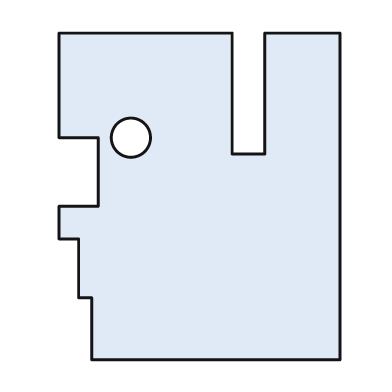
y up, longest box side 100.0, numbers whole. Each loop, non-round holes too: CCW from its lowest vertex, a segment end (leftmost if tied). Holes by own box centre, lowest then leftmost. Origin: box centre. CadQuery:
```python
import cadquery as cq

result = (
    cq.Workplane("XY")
    .moveTo(-33.0, -50.0)
    .lineTo(43.0, -50.0)
    .lineTo(43.0, 50.0)
    .lineTo(20.0, 50.0)
    .lineTo(20.0, 13.0)
    .lineTo(10.0, 13.0)
    .lineTo(10.0, 50.0)
    .lineTo(-43.0, 50.0)
    .lineTo(-43.0, 18.0)
    .lineTo(-31.0, 18.0)
    .lineTo(-31.0, -3.0)
    .lineTo(-43.0, -3.0)
    .lineTo(-43.0, -13.0)
    .lineTo(-37.0, -13.0)
    .lineTo(-37.0, -31.0)
    .lineTo(-33.0, -31.0)
    .close()
    .moveTo(-21.0, 18.0)
    .circle(6.0)
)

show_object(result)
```